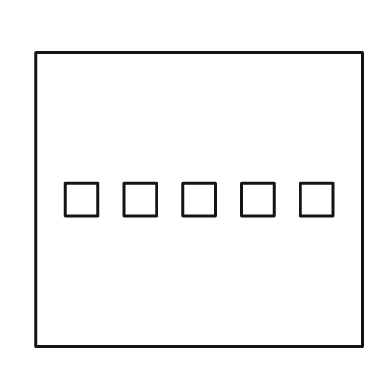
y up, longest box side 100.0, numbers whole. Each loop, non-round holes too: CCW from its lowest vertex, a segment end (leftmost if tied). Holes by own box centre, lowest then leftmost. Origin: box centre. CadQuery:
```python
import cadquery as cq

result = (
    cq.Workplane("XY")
    .moveTo(-50.0, -45.0)
    .lineTo(50.0, -45.0)
    .lineTo(50.0, 45.0)
    .lineTo(-50.0, 45.0)
    .close()
    .moveTo(-41.0, -5.0)
    .lineTo(-31.0, -5.0)
    .lineTo(-31.0, 5.0)
    .lineTo(-41.0, 5.0)
    .close()
    .moveTo(-23.0, -5.0)
    .lineTo(-13.0, -5.0)
    .lineTo(-13.0, 5.0)
    .lineTo(-23.0, 5.0)
    .close()
    .moveTo(-5.0, -5.0)
    .lineTo(5.0, -5.0)
    .lineTo(5.0, 5.0)
    .lineTo(-5.0, 5.0)
    .close()
    .moveTo(13.0, -5.0)
    .lineTo(23.0, -5.0)
    .lineTo(23.0, 5.0)
    .lineTo(13.0, 5.0)
    .close()
    .moveTo(31.0, -5.0)
    .lineTo(41.0, -5.0)
    .lineTo(41.0, 5.0)
    .lineTo(31.0, 5.0)
    .close()
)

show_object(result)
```